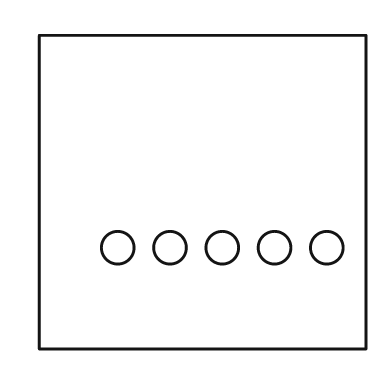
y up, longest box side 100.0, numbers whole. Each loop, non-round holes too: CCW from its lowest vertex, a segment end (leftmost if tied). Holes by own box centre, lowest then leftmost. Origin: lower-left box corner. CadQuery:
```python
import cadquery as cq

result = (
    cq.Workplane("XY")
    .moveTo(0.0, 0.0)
    .lineTo(100.0, 0.0)
    .lineTo(100.0, 96.0)
    .lineTo(0.0, 96.0)
    .close()
    .moveTo(24.0, 31.0)
    .circle(5.0)
    .moveTo(40.0, 31.0)
    .circle(5.0)
    .moveTo(56.0, 31.0)
    .circle(5.0)
    .moveTo(72.0, 31.0)
    .circle(5.0)
    .moveTo(88.0, 31.0)
    .circle(5.0)
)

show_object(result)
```